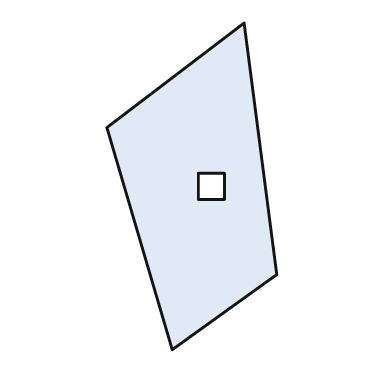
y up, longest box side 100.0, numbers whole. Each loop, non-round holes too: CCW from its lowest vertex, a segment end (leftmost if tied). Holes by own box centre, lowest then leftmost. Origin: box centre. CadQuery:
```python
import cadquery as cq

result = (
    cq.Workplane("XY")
    .moveTo(-6.0, -50.0)
    .lineTo(26.0, -27.0)
    .lineTo(16.0, 50.0)
    .lineTo(-26.0, 18.0)
    .close()
    .moveTo(2.0, -4.0)
    .lineTo(10.0, -4.0)
    .lineTo(10.0, 4.0)
    .lineTo(2.0, 4.0)
    .close()
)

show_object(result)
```